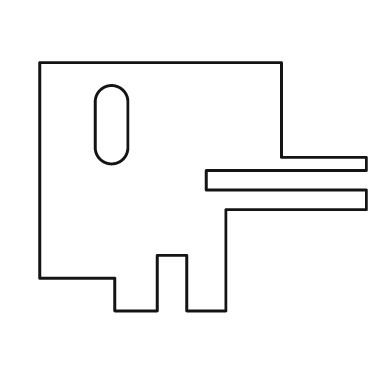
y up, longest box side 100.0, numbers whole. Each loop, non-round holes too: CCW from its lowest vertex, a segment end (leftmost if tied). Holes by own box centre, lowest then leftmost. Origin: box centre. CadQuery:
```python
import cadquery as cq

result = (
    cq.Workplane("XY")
    .moveTo(-27.0, -38.0)
    .lineTo(-14.0, -38.0)
    .lineTo(-14.0, -21.0)
    .lineTo(-5.0, -21.0)
    .lineTo(-5.0, -38.0)
    .lineTo(7.0, -38.0)
    .lineTo(7.0, -7.0)
    .lineTo(50.0, -7.0)
    .lineTo(50.0, -1.0)
    .lineTo(1.0, -1.0)
    .lineTo(1.0, 5.0)
    .lineTo(50.0, 5.0)
    .lineTo(50.0, 9.0)
    .lineTo(24.0, 9.0)
    .lineTo(24.0, 38.0)
    .lineTo(-50.0, 38.0)
    .lineTo(-50.0, -28.0)
    .lineTo(-27.0, -28.0)
    .close()
    .moveTo(-33.0, 12.0)
    .threePointArc((-28.0, 7.0), (-23.0, 12.0))
    .lineTo(-23.0, 26.0)
    .threePointArc((-28.0, 31.0), (-33.0, 26.0))
    .close()
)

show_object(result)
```